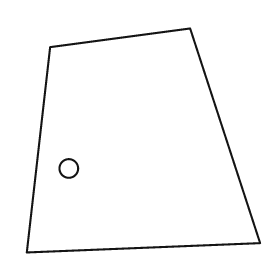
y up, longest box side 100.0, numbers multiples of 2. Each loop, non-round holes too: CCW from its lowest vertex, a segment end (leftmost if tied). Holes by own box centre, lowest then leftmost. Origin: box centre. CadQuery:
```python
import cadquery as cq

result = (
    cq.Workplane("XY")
    .moveTo(-50.0, -48.0)
    .lineTo(50.0, -44.0)
    .lineTo(20.0, 48.0)
    .lineTo(-40.0, 40.0)
    .close()
    .moveTo(-32.0, -12.0)
    .circle(4.0)
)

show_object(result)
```